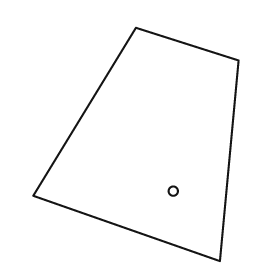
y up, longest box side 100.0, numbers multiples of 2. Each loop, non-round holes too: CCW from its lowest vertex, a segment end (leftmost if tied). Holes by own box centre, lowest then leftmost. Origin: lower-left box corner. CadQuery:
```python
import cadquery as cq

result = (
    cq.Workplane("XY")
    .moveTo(80.0, 0.0)
    .lineTo(88.0, 86.0)
    .lineTo(44.0, 100.0)
    .lineTo(0.0, 28.0)
    .close()
    .moveTo(60.0, 30.0)
    .circle(2.0)
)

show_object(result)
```